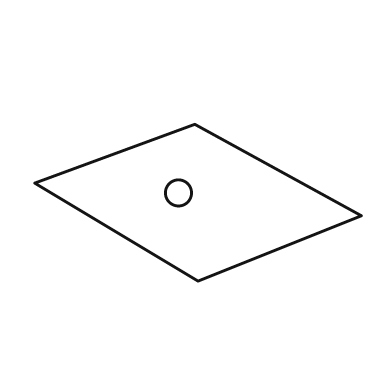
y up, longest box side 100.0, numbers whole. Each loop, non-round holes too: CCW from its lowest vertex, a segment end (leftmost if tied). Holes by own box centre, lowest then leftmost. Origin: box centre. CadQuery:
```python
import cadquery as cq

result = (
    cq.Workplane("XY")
    .moveTo(0.0, -24.0)
    .lineTo(50.0, -4.0)
    .lineTo(-1.0, 24.0)
    .lineTo(-50.0, 6.0)
    .close()
    .moveTo(-6.0, 3.0)
    .circle(4.0)
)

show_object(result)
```